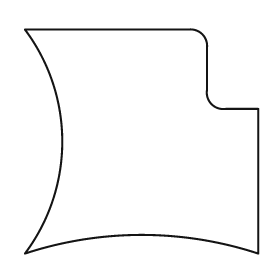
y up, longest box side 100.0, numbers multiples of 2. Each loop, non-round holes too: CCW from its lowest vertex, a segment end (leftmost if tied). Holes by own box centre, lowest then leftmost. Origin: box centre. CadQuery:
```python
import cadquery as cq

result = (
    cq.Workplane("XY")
    .moveTo(-50.0, -48.0)
    .threePointArc((0.0, -40.0), (50.0, -48.0))
    .lineTo(50.0, 14.0)
    .lineTo(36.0, 14.0)
    .threePointArc((30.0, 16.0), (28.0, 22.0))
    .lineTo(28.0, 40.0)
    .threePointArc((26.0, 46.0), (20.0, 48.0))
    .lineTo(-50.0, 48.0)
    .threePointArc((-34.0, 0.0), (-50.0, -48.0))
    .close()
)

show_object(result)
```